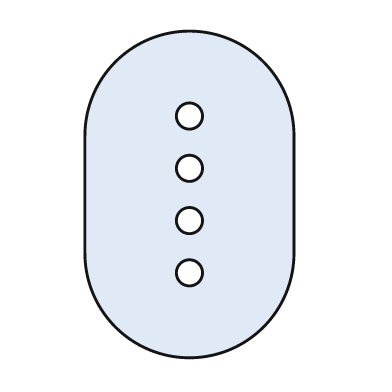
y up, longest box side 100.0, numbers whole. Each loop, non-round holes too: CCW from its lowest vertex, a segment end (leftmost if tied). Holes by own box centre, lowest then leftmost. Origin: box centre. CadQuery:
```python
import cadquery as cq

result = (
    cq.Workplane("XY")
    .moveTo(-32.0, -18.0)
    .threePointArc((0.0, -50.0), (32.0, -18.0))
    .lineTo(32.0, 18.0)
    .threePointArc((0.0, 50.0), (-32.0, 18.0))
    .close()
    .moveTo(0.0, -24.0)
    .circle(4.0)
    .moveTo(0.0, -8.0)
    .circle(4.0)
    .moveTo(0.0, 8.0)
    .circle(4.0)
    .moveTo(0.0, 24.0)
    .circle(4.0)
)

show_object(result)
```